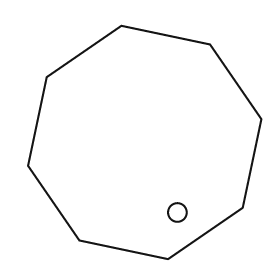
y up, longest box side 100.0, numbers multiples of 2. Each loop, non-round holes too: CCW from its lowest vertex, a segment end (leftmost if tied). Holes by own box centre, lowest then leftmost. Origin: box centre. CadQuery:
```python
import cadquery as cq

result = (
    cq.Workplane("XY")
    .moveTo(10.0, -50.0)
    .lineTo(42.0, -28.0)
    .lineTo(50.0, 10.0)
    .lineTo(28.0, 42.0)
    .lineTo(-10.0, 50.0)
    .lineTo(-42.0, 28.0)
    .lineTo(-50.0, -10.0)
    .lineTo(-28.0, -42.0)
    .close()
    .moveTo(14.0, -30.0)
    .circle(4.0)
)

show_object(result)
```